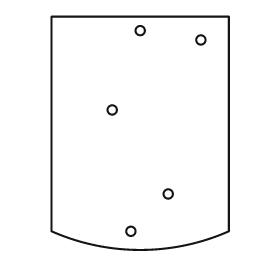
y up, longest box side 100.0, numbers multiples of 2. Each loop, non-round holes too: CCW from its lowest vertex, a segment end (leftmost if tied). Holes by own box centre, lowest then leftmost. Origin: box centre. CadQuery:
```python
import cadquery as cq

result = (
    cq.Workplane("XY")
    .moveTo(-38.0, -42.0)
    .threePointArc((0.0, -50.0), (38.0, -42.0))
    .lineTo(38.0, 50.0)
    .lineTo(-38.0, 50.0)
    .close()
    .moveTo(-4.0, -42.0)
    .circle(2.0)
    .moveTo(12.0, -26.0)
    .circle(2.0)
    .moveTo(-12.0, 10.0)
    .circle(2.0)
    .moveTo(26.0, 40.0)
    .circle(2.0)
    .moveTo(0.0, 44.0)
    .circle(2.0)
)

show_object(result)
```